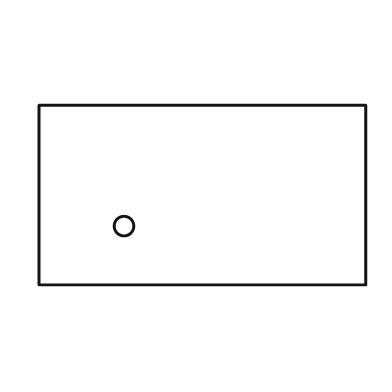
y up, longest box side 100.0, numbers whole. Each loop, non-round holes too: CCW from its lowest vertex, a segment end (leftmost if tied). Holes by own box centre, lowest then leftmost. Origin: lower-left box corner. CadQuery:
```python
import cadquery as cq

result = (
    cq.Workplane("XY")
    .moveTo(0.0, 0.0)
    .lineTo(100.0, 0.0)
    .lineTo(100.0, 55.0)
    .lineTo(0.0, 55.0)
    .close()
    .moveTo(26.0, 18.0)
    .circle(3.0)
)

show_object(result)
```